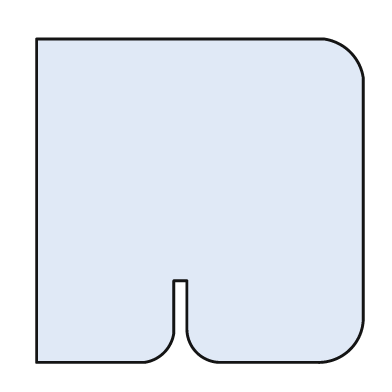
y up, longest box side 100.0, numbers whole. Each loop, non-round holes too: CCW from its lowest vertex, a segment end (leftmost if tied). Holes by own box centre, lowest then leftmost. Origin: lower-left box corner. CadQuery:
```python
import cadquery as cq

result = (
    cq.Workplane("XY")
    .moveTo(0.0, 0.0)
    .lineTo(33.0, 0.0)
    .threePointArc((39.0, 3.0), (42.0, 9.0))
    .lineTo(42.0, 25.0)
    .lineTo(46.0, 25.0)
    .lineTo(46.0, 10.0)
    .threePointArc((49.0, 3.0), (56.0, 0.0))
    .lineTo(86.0, 0.0)
    .threePointArc((96.0, 4.0), (100.0, 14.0))
    .lineTo(100.0, 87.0)
    .threePointArc((96.0, 95.0), (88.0, 99.0))
    .lineTo(0.0, 99.0)
    .close()
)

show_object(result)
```